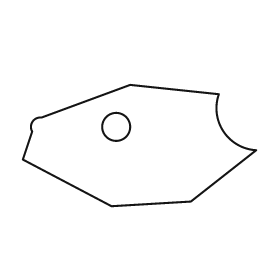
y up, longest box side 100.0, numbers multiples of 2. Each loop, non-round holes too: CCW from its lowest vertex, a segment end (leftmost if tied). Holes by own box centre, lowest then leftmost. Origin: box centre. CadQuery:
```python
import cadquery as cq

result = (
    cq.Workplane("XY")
    .moveTo(-12.0, -26.0)
    .lineTo(22.0, -24.0)
    .lineTo(50.0, -2.0)
    .threePointArc((36.0, 6.0), (34.0, 22.0))
    .lineTo(-4.0, 26.0)
    .lineTo(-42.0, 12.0)
    .threePointArc((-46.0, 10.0), (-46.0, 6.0))
    .lineTo(-50.0, -6.0)
    .close()
    .moveTo(-10.0, 8.0)
    .circle(6.0)
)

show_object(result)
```